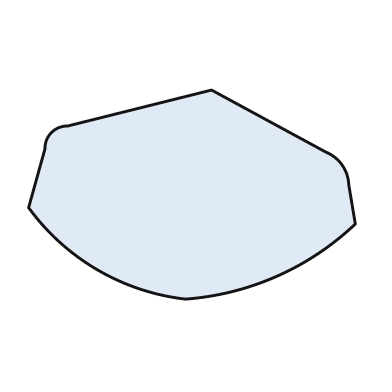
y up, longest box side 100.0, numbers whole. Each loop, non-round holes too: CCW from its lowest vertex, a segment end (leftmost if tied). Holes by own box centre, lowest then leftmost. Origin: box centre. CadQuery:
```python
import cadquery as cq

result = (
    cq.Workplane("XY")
    .moveTo(-2.0, -32.0)
    .threePointArc((26.0, -25.0), (50.0, -9.0))
    .lineTo(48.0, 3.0)
    .threePointArc((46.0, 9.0), (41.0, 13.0))
    .lineTo(6.0, 32.0)
    .lineTo(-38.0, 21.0)
    .threePointArc((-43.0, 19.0), (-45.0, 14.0))
    .lineTo(-50.0, -4.0)
    .threePointArc((-29.0, -23.0), (-2.0, -32.0))
    .close()
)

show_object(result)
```